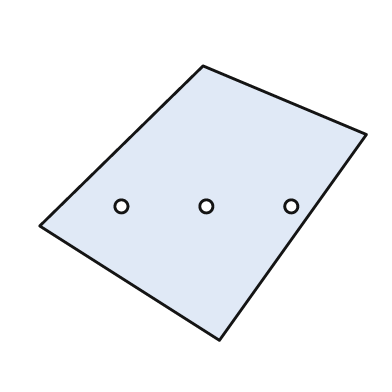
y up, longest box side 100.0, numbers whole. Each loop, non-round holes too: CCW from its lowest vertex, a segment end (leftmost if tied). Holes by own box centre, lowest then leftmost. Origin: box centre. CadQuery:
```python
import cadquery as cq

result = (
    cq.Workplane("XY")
    .moveTo(5.0, -42.0)
    .lineTo(50.0, 21.0)
    .lineTo(0.0, 42.0)
    .lineTo(-50.0, -7.0)
    .close()
    .moveTo(-25.0, -1.0)
    .circle(2.0)
    .moveTo(1.0, -1.0)
    .circle(2.0)
    .moveTo(27.0, -1.0)
    .circle(2.0)
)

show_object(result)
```